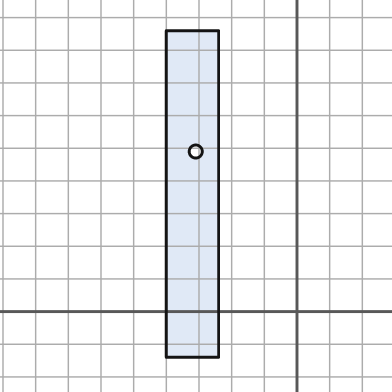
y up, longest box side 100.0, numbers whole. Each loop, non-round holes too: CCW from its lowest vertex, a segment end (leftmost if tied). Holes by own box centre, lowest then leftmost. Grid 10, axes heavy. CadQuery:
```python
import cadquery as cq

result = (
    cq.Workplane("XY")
    .moveTo(-40.0, -14.0)
    .lineTo(-24.0, -14.0)
    .lineTo(-24.0, 86.0)
    .lineTo(-40.0, 86.0)
    .close()
    .moveTo(-31.0, 49.0)
    .circle(2.0)
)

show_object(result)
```